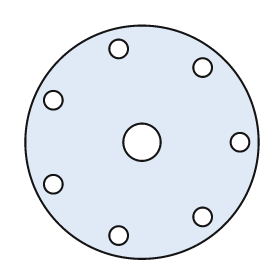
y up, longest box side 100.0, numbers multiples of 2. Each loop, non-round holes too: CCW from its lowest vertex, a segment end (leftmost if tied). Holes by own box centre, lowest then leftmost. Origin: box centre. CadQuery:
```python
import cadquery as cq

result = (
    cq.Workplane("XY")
    .moveTo(0.0, 0.0)
    .circle(50.0)
    .moveTo(-10.0, -40.0)
    .circle(4.0)
    .moveTo(26.0, -32.0)
    .circle(4.0)
    .moveTo(-38.0, -18.0)
    .circle(4.0)
    .moveTo(0.0, 0.0)
    .circle(8.0)
    .moveTo(42.0, 0.0)
    .circle(4.0)
    .moveTo(-38.0, 18.0)
    .circle(4.0)
    .moveTo(26.0, 32.0)
    .circle(4.0)
    .moveTo(-10.0, 40.0)
    .circle(4.0)
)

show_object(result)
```